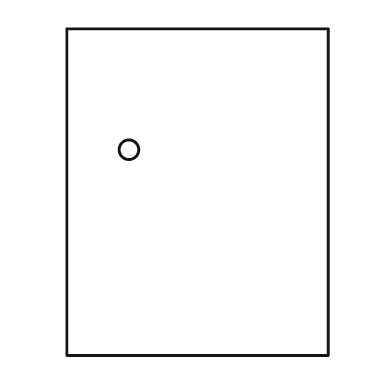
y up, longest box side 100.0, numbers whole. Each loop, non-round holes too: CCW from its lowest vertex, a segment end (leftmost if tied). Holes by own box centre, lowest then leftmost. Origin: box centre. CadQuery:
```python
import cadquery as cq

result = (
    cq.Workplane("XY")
    .moveTo(-40.0, -50.0)
    .lineTo(40.0, -50.0)
    .lineTo(40.0, 50.0)
    .lineTo(-40.0, 50.0)
    .close()
    .moveTo(-21.0, 13.0)
    .circle(3.0)
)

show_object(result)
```